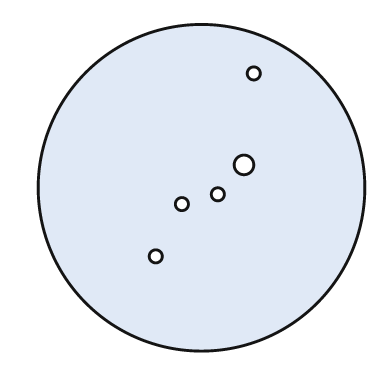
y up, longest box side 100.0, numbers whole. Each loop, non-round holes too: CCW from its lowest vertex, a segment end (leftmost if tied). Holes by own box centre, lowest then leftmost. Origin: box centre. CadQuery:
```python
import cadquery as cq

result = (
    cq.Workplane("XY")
    .moveTo(0.0, 0.0)
    .circle(50.0)
    .moveTo(-14.0, -21.0)
    .circle(2.0)
    .moveTo(-6.0, -5.0)
    .circle(2.0)
    .moveTo(5.0, -2.0)
    .circle(2.0)
    .moveTo(13.0, 7.0)
    .circle(3.0)
    .moveTo(16.0, 35.0)
    .circle(2.0)
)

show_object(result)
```